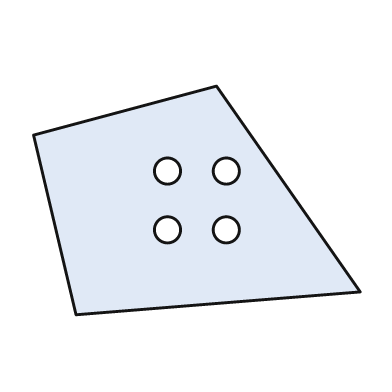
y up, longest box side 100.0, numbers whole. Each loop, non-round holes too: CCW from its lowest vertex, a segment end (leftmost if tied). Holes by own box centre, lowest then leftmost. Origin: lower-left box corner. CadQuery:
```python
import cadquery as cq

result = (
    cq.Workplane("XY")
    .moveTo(13.0, 0.0)
    .lineTo(100.0, 7.0)
    .lineTo(56.0, 70.0)
    .lineTo(0.0, 55.0)
    .close()
    .moveTo(41.0, 26.0)
    .circle(4.0)
    .moveTo(59.0, 26.0)
    .circle(4.0)
    .moveTo(41.0, 44.0)
    .circle(4.0)
    .moveTo(59.0, 44.0)
    .circle(4.0)
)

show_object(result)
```